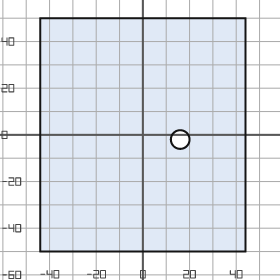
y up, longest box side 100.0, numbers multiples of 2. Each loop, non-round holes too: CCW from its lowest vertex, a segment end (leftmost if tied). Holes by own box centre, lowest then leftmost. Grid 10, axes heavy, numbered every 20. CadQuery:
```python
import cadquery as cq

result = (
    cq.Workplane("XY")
    .moveTo(-44.0, -50.0)
    .lineTo(44.0, -50.0)
    .lineTo(44.0, 50.0)
    .lineTo(-44.0, 50.0)
    .close()
    .moveTo(16.0, -2.0)
    .circle(4.0)
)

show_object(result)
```